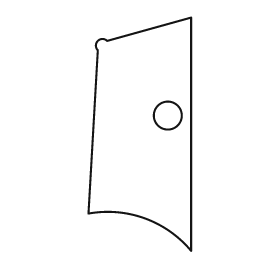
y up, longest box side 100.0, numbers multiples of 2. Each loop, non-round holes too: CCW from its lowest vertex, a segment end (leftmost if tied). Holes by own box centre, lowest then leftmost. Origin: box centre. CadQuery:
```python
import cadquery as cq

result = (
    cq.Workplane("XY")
    .moveTo(22.0, -50.0)
    .lineTo(22.0, 50.0)
    .lineTo(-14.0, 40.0)
    .threePointArc((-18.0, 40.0), (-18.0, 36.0))
    .lineTo(-22.0, -34.0)
    .threePointArc((2.0, -36.0), (22.0, -50.0))
    .close()
    .moveTo(12.0, 8.0)
    .circle(6.0)
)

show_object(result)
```